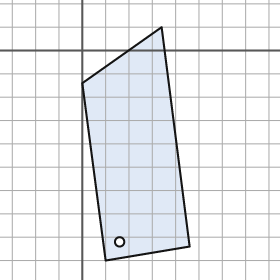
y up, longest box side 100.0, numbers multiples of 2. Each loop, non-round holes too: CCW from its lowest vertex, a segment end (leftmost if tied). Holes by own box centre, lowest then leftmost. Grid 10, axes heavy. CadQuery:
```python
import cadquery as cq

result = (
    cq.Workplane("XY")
    .moveTo(10.0, -90.0)
    .lineTo(46.0, -84.0)
    .lineTo(34.0, 10.0)
    .lineTo(0.0, -14.0)
    .close()
    .moveTo(16.0, -82.0)
    .circle(2.0)
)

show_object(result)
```